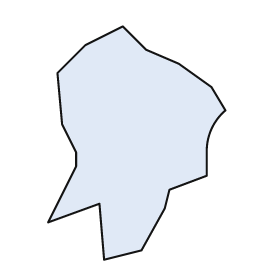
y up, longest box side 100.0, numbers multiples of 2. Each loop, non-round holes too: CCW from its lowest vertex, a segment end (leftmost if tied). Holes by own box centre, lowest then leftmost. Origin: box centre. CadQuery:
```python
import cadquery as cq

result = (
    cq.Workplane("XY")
    .moveTo(-14.0, -50.0)
    .lineTo(2.0, -46.0)
    .lineTo(12.0, -28.0)
    .lineTo(14.0, -20.0)
    .lineTo(30.0, -14.0)
    .lineTo(30.0, -4.0)
    .threePointArc((32.0, 6.0), (38.0, 14.0))
    .lineTo(32.0, 24.0)
    .lineTo(18.0, 34.0)
    .lineTo(4.0, 40.0)
    .lineTo(-6.0, 50.0)
    .lineTo(-22.0, 42.0)
    .lineTo(-34.0, 30.0)
    .lineTo(-32.0, 8.0)
    .lineTo(-26.0, -4.0)
    .lineTo(-26.0, -10.0)
    .lineTo(-38.0, -34.0)
    .lineTo(-16.0, -26.0)
    .close()
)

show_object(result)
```